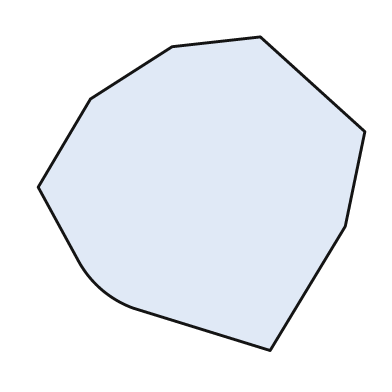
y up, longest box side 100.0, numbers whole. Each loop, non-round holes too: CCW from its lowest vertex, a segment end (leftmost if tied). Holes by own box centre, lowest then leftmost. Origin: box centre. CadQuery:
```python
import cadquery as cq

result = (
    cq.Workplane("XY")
    .moveTo(21.0, -48.0)
    .lineTo(44.0, -10.0)
    .lineTo(50.0, 19.0)
    .lineTo(18.0, 48.0)
    .lineTo(-9.0, 45.0)
    .lineTo(-34.0, 29.0)
    .lineTo(-50.0, 2.0)
    .lineTo(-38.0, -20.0)
    .threePointArc((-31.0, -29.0), (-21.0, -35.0))
    .close()
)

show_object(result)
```